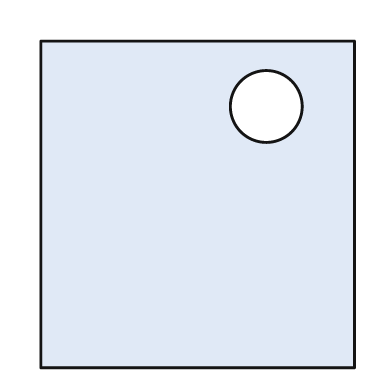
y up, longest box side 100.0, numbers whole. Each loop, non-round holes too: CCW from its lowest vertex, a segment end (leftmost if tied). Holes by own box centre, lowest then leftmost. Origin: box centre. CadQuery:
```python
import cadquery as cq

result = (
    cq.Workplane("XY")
    .moveTo(-48.0, -50.0)
    .lineTo(48.0, -50.0)
    .lineTo(48.0, 50.0)
    .lineTo(-48.0, 50.0)
    .close()
    .moveTo(21.0, 30.0)
    .circle(11.0)
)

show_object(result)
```